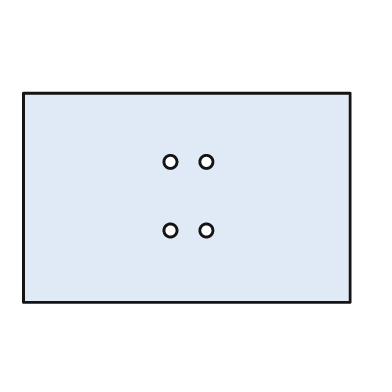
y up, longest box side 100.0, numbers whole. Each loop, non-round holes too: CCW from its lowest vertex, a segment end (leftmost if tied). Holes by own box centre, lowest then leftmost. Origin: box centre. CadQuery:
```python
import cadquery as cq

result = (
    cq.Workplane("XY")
    .moveTo(-50.0, -32.0)
    .lineTo(50.0, -32.0)
    .lineTo(50.0, 32.0)
    .lineTo(-50.0, 32.0)
    .close()
    .moveTo(-5.0, -10.0)
    .circle(2.0)
    .moveTo(6.0, -10.0)
    .circle(2.0)
    .moveTo(-5.0, 11.0)
    .circle(2.0)
    .moveTo(6.0, 11.0)
    .circle(2.0)
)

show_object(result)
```